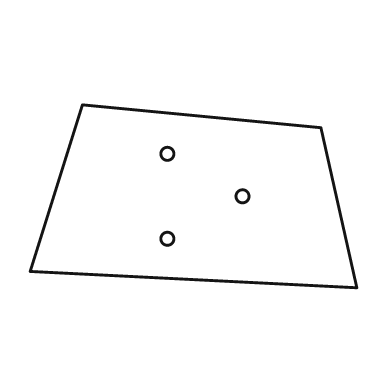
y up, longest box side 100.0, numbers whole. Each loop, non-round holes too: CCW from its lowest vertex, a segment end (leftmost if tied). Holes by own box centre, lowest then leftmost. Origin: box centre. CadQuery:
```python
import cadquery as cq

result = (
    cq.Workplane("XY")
    .moveTo(50.0, -28.0)
    .lineTo(39.0, 21.0)
    .lineTo(-34.0, 28.0)
    .lineTo(-50.0, -23.0)
    .close()
    .moveTo(-8.0, -13.0)
    .circle(2.0)
    .moveTo(15.0, 0.0)
    .circle(2.0)
    .moveTo(-8.0, 13.0)
    .circle(2.0)
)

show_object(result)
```